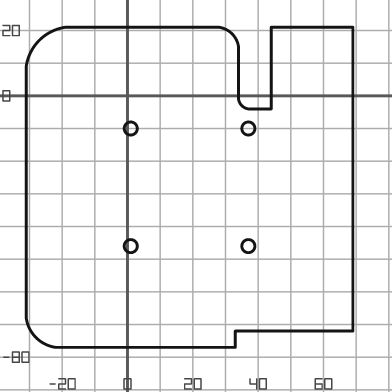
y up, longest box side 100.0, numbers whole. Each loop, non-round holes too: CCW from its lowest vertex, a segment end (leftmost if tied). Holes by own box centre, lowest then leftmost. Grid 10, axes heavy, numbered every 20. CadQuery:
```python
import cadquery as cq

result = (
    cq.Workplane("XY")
    .moveTo(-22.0, -77.0)
    .lineTo(33.0, -77.0)
    .lineTo(33.0, -72.0)
    .lineTo(69.0, -72.0)
    .lineTo(69.0, 21.0)
    .lineTo(44.0, 21.0)
    .lineTo(44.0, -4.0)
    .lineTo(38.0, -4.0)
    .threePointArc((35.0, -3.0), (34.0, 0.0))
    .lineTo(34.0, 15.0)
    .threePointArc((32.0, 19.0), (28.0, 21.0))
    .lineTo(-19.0, 21.0)
    .threePointArc((-27.0, 17.0), (-31.0, 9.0))
    .lineTo(-31.0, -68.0)
    .threePointArc((-28.0, -74.0), (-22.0, -77.0))
    .close()
    .moveTo(1.0, -46.0)
    .circle(2.0)
    .moveTo(37.0, -46.0)
    .circle(2.0)
    .moveTo(1.0, -10.0)
    .circle(2.0)
    .moveTo(37.0, -10.0)
    .circle(2.0)
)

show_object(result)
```